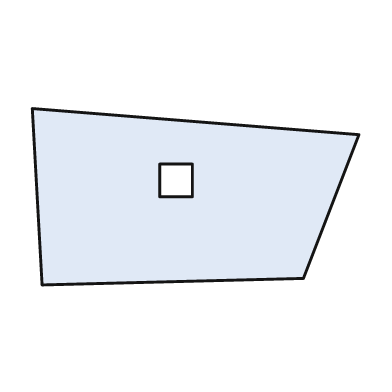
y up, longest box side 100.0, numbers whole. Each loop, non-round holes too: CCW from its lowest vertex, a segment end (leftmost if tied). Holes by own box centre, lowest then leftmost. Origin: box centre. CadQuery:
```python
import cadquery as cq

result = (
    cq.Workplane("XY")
    .moveTo(-47.0, -27.0)
    .lineTo(33.0, -25.0)
    .lineTo(50.0, 19.0)
    .lineTo(-50.0, 27.0)
    .close()
    .moveTo(-11.0, 0.0)
    .lineTo(-1.0, 0.0)
    .lineTo(-1.0, 10.0)
    .lineTo(-11.0, 10.0)
    .close()
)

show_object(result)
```